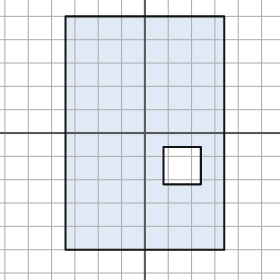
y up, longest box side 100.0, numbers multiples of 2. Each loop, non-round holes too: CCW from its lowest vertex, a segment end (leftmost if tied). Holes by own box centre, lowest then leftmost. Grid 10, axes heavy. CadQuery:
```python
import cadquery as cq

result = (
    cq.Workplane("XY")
    .moveTo(-34.0, -50.0)
    .lineTo(34.0, -50.0)
    .lineTo(34.0, 50.0)
    .lineTo(-34.0, 50.0)
    .close()
    .moveTo(8.0, -22.0)
    .lineTo(24.0, -22.0)
    .lineTo(24.0, -6.0)
    .lineTo(8.0, -6.0)
    .close()
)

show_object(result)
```